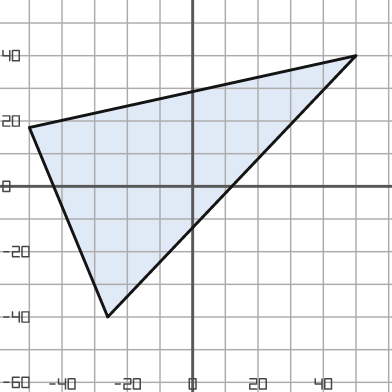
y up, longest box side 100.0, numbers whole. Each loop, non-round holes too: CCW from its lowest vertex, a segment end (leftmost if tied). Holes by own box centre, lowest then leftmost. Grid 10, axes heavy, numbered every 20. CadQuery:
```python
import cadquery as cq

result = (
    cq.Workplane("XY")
    .moveTo(-26.0, -40.0)
    .lineTo(50.0, 40.0)
    .lineTo(-50.0, 18.0)
    .close()
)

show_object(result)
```